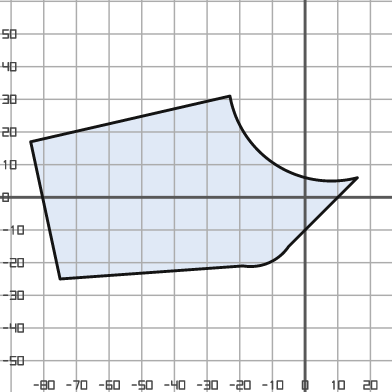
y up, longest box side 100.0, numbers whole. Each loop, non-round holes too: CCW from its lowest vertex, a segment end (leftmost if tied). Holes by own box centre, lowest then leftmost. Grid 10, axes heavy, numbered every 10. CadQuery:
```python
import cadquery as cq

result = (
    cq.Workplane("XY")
    .moveTo(-75.0, -25.0)
    .lineTo(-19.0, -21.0)
    .threePointArc((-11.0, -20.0), (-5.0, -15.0))
    .lineTo(16.0, 6.0)
    .threePointArc((-9.0, 10.0), (-23.0, 31.0))
    .lineTo(-84.0, 17.0)
    .close()
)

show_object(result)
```